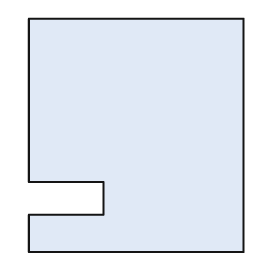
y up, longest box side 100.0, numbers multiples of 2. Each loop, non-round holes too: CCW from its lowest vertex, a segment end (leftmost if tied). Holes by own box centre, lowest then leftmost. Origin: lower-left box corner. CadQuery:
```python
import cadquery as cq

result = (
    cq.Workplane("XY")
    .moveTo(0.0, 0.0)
    .lineTo(92.0, 0.0)
    .lineTo(92.0, 100.0)
    .lineTo(0.0, 100.0)
    .lineTo(0.0, 30.0)
    .lineTo(32.0, 30.0)
    .lineTo(32.0, 16.0)
    .lineTo(0.0, 16.0)
    .close()
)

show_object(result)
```